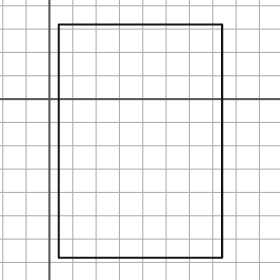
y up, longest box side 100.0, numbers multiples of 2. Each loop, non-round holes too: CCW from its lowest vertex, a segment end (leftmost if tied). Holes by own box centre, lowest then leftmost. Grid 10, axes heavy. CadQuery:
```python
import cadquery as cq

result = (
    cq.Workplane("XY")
    .moveTo(4.0, -68.0)
    .lineTo(74.0, -68.0)
    .lineTo(74.0, 32.0)
    .lineTo(4.0, 32.0)
    .close()
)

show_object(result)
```